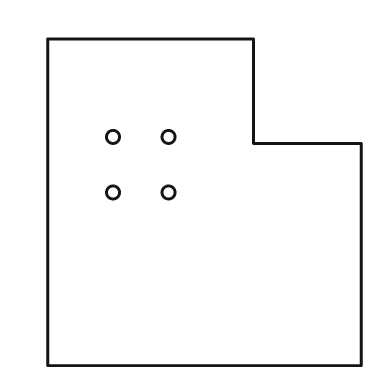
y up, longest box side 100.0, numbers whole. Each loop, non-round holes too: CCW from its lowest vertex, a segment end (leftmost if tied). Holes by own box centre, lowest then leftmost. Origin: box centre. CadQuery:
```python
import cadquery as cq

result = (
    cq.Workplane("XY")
    .moveTo(-48.0, -50.0)
    .lineTo(48.0, -50.0)
    .lineTo(48.0, 18.0)
    .lineTo(15.0, 18.0)
    .lineTo(15.0, 50.0)
    .lineTo(-48.0, 50.0)
    .close()
    .moveTo(-28.0, 3.0)
    .circle(2.0)
    .moveTo(-11.0, 3.0)
    .circle(2.0)
    .moveTo(-28.0, 20.0)
    .circle(2.0)
    .moveTo(-11.0, 20.0)
    .circle(2.0)
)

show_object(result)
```